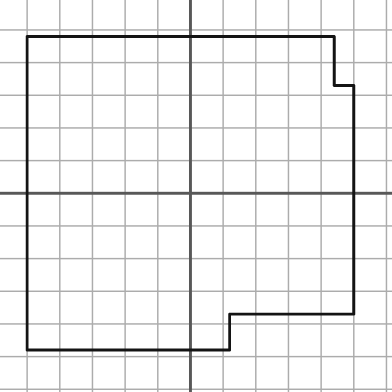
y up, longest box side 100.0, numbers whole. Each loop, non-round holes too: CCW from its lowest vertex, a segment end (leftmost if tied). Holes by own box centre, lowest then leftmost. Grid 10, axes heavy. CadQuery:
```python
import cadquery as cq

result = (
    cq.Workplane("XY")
    .moveTo(-50.0, -48.0)
    .lineTo(12.0, -48.0)
    .lineTo(12.0, -37.0)
    .lineTo(50.0, -37.0)
    .lineTo(50.0, 33.0)
    .lineTo(44.0, 33.0)
    .lineTo(44.0, 48.0)
    .lineTo(-50.0, 48.0)
    .close()
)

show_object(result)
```